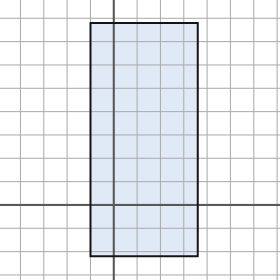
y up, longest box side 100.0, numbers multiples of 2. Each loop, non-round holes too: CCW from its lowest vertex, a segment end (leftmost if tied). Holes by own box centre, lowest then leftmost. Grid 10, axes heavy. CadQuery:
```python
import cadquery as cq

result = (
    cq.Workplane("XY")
    .moveTo(-10.0, -22.0)
    .lineTo(36.0, -22.0)
    .lineTo(36.0, 78.0)
    .lineTo(-10.0, 78.0)
    .close()
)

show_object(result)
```